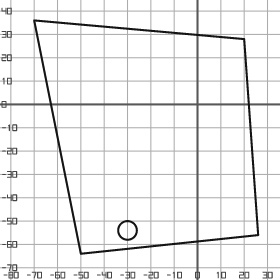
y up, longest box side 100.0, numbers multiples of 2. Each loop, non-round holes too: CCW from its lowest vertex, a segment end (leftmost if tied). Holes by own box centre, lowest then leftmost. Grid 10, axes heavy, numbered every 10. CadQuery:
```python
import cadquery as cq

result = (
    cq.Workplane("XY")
    .moveTo(-50.0, -64.0)
    .lineTo(26.0, -56.0)
    .lineTo(20.0, 28.0)
    .lineTo(-70.0, 36.0)
    .close()
    .moveTo(-30.0, -54.0)
    .circle(4.0)
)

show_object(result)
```